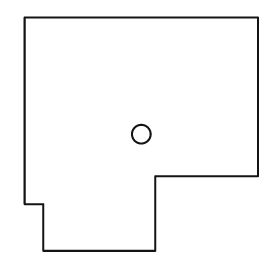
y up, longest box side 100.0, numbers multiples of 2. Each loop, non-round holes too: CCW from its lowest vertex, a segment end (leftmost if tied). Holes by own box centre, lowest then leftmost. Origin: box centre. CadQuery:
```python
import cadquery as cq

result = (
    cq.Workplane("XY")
    .moveTo(-42.0, -50.0)
    .lineTo(6.0, -50.0)
    .lineTo(6.0, -18.0)
    .lineTo(50.0, -18.0)
    .lineTo(50.0, 50.0)
    .lineTo(-50.0, 50.0)
    .lineTo(-50.0, -30.0)
    .lineTo(-42.0, -30.0)
    .close()
    .moveTo(0.0, 0.0)
    .circle(4.0)
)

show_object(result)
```